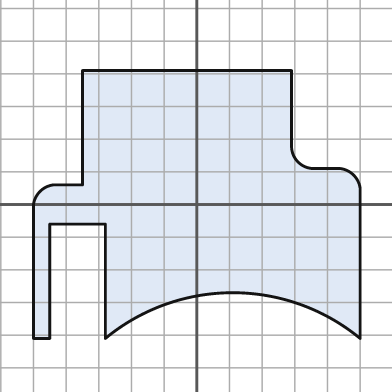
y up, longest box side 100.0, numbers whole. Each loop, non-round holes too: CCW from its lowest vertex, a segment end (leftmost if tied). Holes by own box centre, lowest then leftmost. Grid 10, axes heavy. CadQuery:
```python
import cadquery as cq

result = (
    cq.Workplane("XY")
    .moveTo(-50.0, -41.0)
    .lineTo(-45.0, -41.0)
    .lineTo(-45.0, -6.0)
    .lineTo(-28.0, -6.0)
    .lineTo(-28.0, -41.0)
    .threePointArc((11.0, -27.0), (50.0, -41.0))
    .lineTo(50.0, 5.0)
    .threePointArc((48.0, 9.0), (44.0, 11.0))
    .lineTo(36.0, 11.0)
    .threePointArc((31.0, 13.0), (29.0, 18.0))
    .lineTo(29.0, 41.0)
    .lineTo(-35.0, 41.0)
    .lineTo(-35.0, 6.0)
    .lineTo(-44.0, 6.0)
    .threePointArc((-48.0, 4.0), (-50.0, 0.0))
    .close()
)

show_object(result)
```